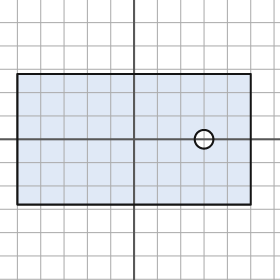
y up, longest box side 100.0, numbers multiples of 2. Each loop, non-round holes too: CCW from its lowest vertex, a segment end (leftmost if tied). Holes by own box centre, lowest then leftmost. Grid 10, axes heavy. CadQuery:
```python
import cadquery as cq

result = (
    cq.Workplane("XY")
    .moveTo(-50.0, -28.0)
    .lineTo(50.0, -28.0)
    .lineTo(50.0, 28.0)
    .lineTo(-50.0, 28.0)
    .close()
    .moveTo(30.0, 0.0)
    .circle(4.0)
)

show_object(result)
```